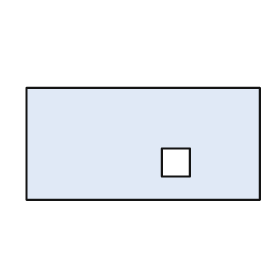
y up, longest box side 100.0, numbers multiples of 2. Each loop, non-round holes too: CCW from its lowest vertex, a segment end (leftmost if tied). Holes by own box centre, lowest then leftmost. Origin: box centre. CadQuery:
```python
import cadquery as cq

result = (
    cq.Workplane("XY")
    .moveTo(-50.0, -24.0)
    .lineTo(50.0, -24.0)
    .lineTo(50.0, 24.0)
    .lineTo(-50.0, 24.0)
    .close()
    .moveTo(8.0, -14.0)
    .lineTo(20.0, -14.0)
    .lineTo(20.0, -2.0)
    .lineTo(8.0, -2.0)
    .close()
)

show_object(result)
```